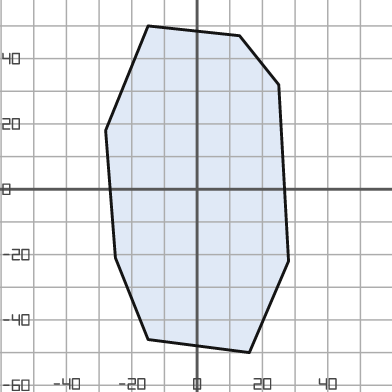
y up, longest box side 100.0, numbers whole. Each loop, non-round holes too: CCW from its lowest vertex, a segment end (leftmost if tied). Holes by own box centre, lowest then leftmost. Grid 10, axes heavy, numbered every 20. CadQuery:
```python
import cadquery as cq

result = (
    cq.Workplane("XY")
    .moveTo(16.0, -50.0)
    .lineTo(28.0, -22.0)
    .lineTo(25.0, 32.0)
    .lineTo(13.0, 47.0)
    .lineTo(-15.0, 50.0)
    .lineTo(-28.0, 18.0)
    .lineTo(-25.0, -21.0)
    .lineTo(-15.0, -46.0)
    .close()
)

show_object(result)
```